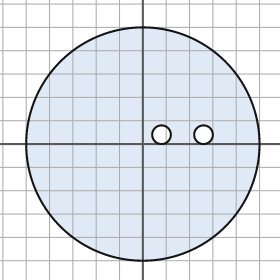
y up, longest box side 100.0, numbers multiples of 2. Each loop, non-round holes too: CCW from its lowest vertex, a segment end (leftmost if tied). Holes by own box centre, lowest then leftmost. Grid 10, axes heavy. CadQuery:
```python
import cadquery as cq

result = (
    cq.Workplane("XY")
    .moveTo(0.0, 0.0)
    .circle(50.0)
    .moveTo(8.0, 4.0)
    .circle(4.0)
    .moveTo(26.0, 4.0)
    .circle(4.0)
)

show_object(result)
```